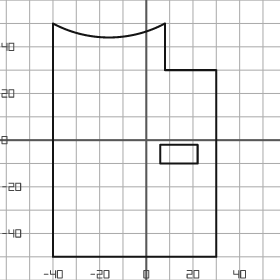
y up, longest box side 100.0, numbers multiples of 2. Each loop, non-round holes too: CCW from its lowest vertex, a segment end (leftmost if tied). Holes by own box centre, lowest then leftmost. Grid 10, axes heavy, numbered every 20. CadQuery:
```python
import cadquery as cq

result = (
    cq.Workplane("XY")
    .moveTo(-40.0, -50.0)
    .lineTo(30.0, -50.0)
    .lineTo(30.0, 30.0)
    .lineTo(8.0, 30.0)
    .lineTo(8.0, 50.0)
    .threePointArc((-16.0, 44.0), (-40.0, 50.0))
    .close()
    .moveTo(6.0, -10.0)
    .lineTo(22.0, -10.0)
    .lineTo(22.0, -2.0)
    .lineTo(6.0, -2.0)
    .close()
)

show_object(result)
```